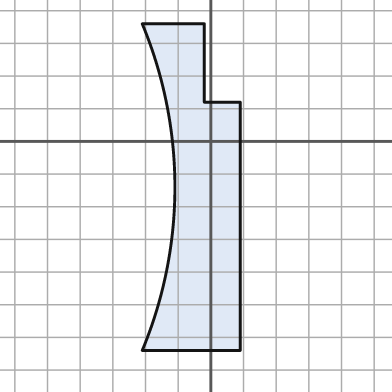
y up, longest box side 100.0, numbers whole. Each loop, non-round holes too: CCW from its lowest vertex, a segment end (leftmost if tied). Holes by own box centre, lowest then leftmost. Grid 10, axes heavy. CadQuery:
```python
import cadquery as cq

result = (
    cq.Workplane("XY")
    .moveTo(-21.0, -64.0)
    .lineTo(9.0, -64.0)
    .lineTo(9.0, 12.0)
    .lineTo(-2.0, 12.0)
    .lineTo(-2.0, 36.0)
    .lineTo(-21.0, 36.0)
    .threePointArc((-11.0, -14.0), (-21.0, -64.0))
    .close()
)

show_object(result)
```